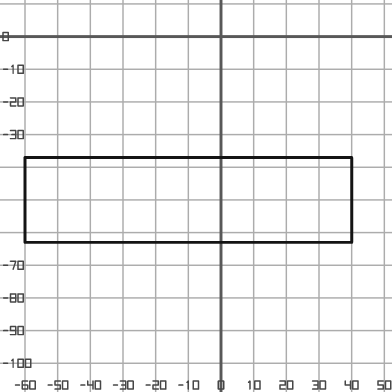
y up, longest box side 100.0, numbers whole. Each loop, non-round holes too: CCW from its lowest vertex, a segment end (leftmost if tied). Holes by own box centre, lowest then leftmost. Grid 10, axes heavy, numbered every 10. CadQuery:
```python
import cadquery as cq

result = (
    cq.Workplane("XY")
    .moveTo(-60.0, -63.0)
    .lineTo(40.0, -63.0)
    .lineTo(40.0, -37.0)
    .lineTo(-60.0, -37.0)
    .close()
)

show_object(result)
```